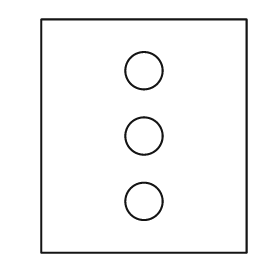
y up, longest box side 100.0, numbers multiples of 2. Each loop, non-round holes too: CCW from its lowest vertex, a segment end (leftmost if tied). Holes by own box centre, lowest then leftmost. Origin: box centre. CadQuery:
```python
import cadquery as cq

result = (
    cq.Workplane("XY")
    .moveTo(-44.0, -50.0)
    .lineTo(44.0, -50.0)
    .lineTo(44.0, 50.0)
    .lineTo(-44.0, 50.0)
    .close()
    .moveTo(0.0, -28.0)
    .circle(8.0)
    .moveTo(0.0, 0.0)
    .circle(8.0)
    .moveTo(0.0, 28.0)
    .circle(8.0)
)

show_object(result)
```